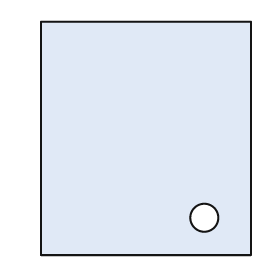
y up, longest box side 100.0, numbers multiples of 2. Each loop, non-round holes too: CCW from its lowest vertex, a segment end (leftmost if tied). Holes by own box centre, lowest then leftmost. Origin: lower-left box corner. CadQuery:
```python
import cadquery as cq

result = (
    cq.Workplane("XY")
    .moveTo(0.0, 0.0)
    .lineTo(90.0, 0.0)
    .lineTo(90.0, 100.0)
    .lineTo(0.0, 100.0)
    .close()
    .moveTo(70.0, 16.0)
    .circle(6.0)
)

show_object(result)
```